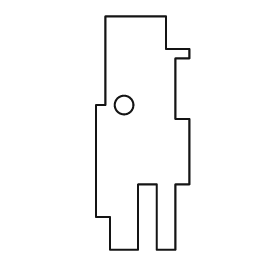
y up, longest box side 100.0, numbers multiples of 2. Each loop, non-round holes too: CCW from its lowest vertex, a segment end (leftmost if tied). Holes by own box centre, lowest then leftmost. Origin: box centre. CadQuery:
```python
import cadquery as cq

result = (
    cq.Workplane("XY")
    .moveTo(-14.0, -50.0)
    .lineTo(-2.0, -50.0)
    .lineTo(-2.0, -22.0)
    .lineTo(6.0, -22.0)
    .lineTo(6.0, -50.0)
    .lineTo(14.0, -50.0)
    .lineTo(14.0, -22.0)
    .lineTo(20.0, -22.0)
    .lineTo(20.0, 6.0)
    .lineTo(14.0, 6.0)
    .lineTo(14.0, 32.0)
    .lineTo(20.0, 32.0)
    .lineTo(20.0, 36.0)
    .lineTo(10.0, 36.0)
    .lineTo(10.0, 50.0)
    .lineTo(-16.0, 50.0)
    .lineTo(-16.0, 12.0)
    .lineTo(-20.0, 12.0)
    .lineTo(-20.0, -36.0)
    .lineTo(-14.0, -36.0)
    .close()
    .moveTo(-8.0, 12.0)
    .circle(4.0)
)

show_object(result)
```